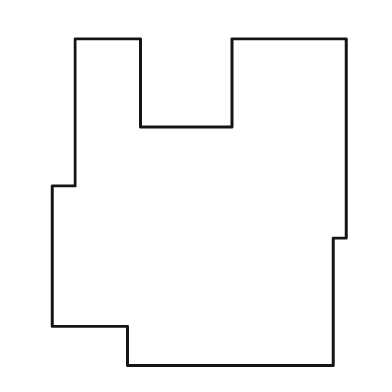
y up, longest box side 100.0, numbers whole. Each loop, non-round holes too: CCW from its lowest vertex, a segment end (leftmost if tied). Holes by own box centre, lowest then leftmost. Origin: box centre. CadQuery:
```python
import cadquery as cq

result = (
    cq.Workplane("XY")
    .moveTo(-22.0, -50.0)
    .lineTo(41.0, -50.0)
    .lineTo(41.0, -11.0)
    .lineTo(45.0, -11.0)
    .lineTo(45.0, 50.0)
    .lineTo(10.0, 50.0)
    .lineTo(10.0, 23.0)
    .lineTo(-18.0, 23.0)
    .lineTo(-18.0, 50.0)
    .lineTo(-38.0, 50.0)
    .lineTo(-38.0, 5.0)
    .lineTo(-45.0, 5.0)
    .lineTo(-45.0, -38.0)
    .lineTo(-22.0, -38.0)
    .close()
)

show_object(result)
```